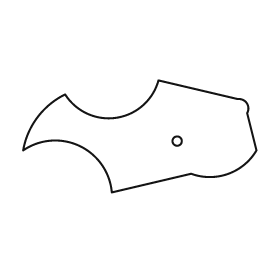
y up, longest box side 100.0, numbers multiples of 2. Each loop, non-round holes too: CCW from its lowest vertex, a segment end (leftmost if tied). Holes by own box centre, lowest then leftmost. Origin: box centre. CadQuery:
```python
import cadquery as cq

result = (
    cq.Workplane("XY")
    .moveTo(-12.0, -24.0)
    .lineTo(22.0, -16.0)
    .threePointArc((38.0, -16.0), (50.0, -6.0))
    .lineTo(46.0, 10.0)
    .threePointArc((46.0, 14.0), (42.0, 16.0))
    .lineTo(8.0, 24.0)
    .threePointArc((-10.0, 8.0), (-32.0, 18.0))
    .threePointArc((-44.0, 8.0), (-50.0, -6.0))
    .threePointArc((-26.0, -4.0), (-12.0, -24.0))
    .close()
    .moveTo(16.0, -2.0)
    .circle(2.0)
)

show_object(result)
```